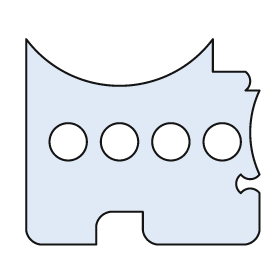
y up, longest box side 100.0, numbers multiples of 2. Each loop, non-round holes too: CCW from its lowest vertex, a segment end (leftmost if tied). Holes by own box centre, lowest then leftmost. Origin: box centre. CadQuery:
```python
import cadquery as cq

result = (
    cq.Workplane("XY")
    .moveTo(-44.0, -44.0)
    .lineTo(-20.0, -44.0)
    .lineTo(-20.0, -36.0)
    .threePointArc((-18.0, -32.0), (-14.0, -30.0))
    .lineTo(0.0, -30.0)
    .lineTo(0.0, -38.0)
    .threePointArc((2.0, -42.0), (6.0, -44.0))
    .lineTo(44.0, -44.0)
    .threePointArc((48.0, -42.0), (50.0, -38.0))
    .lineTo(50.0, -22.0)
    .threePointArc((46.0, -20.0), (42.0, -22.0))
    .threePointArc((40.0, -18.0), (42.0, -14.0))
    .threePointArc((46.0, -16.0), (50.0, -14.0))
    .threePointArc((46.0, 4.0), (50.0, 22.0))
    .lineTo(44.0, 22.0)
    .threePointArc((46.0, 26.0), (44.0, 30.0))
    .lineTo(30.0, 30.0)
    .lineTo(30.0, 44.0)
    .threePointArc((-10.0, 24.0), (-50.0, 44.0))
    .lineTo(-50.0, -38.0)
    .threePointArc((-48.0, -42.0), (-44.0, -44.0))
    .close()
    .moveTo(-32.0, 0.0)
    .circle(8.0)
    .moveTo(-10.0, 0.0)
    .circle(8.0)
    .moveTo(12.0, 0.0)
    .circle(8.0)
    .moveTo(34.0, 0.0)
    .circle(8.0)
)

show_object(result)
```